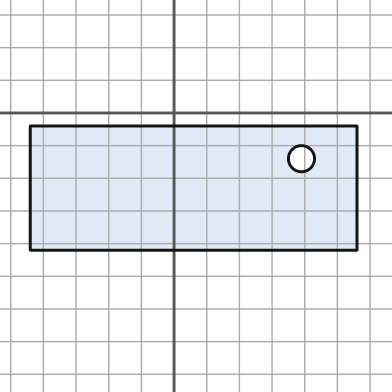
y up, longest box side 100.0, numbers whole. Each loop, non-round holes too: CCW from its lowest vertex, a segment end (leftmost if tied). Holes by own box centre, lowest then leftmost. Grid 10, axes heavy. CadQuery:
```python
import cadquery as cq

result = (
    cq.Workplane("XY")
    .moveTo(-44.0, -42.0)
    .lineTo(56.0, -42.0)
    .lineTo(56.0, -4.0)
    .lineTo(-44.0, -4.0)
    .close()
    .moveTo(39.0, -14.0)
    .circle(4.0)
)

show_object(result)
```